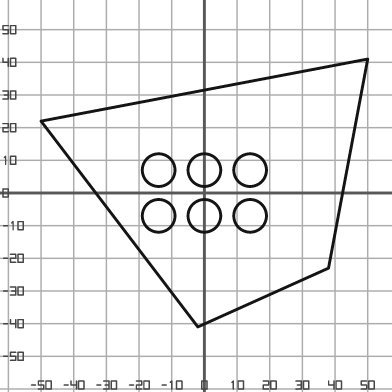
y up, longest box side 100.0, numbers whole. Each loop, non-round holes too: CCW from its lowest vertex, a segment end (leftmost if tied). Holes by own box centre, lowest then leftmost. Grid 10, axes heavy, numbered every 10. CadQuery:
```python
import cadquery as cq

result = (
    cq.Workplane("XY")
    .moveTo(-2.0, -41.0)
    .lineTo(38.0, -23.0)
    .lineTo(50.0, 41.0)
    .lineTo(-50.0, 22.0)
    .close()
    .moveTo(-14.0, -7.0)
    .circle(5.0)
    .moveTo(0.0, -7.0)
    .circle(5.0)
    .moveTo(14.0, -7.0)
    .circle(5.0)
    .moveTo(-14.0, 7.0)
    .circle(5.0)
    .moveTo(0.0, 7.0)
    .circle(5.0)
    .moveTo(14.0, 7.0)
    .circle(5.0)
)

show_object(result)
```